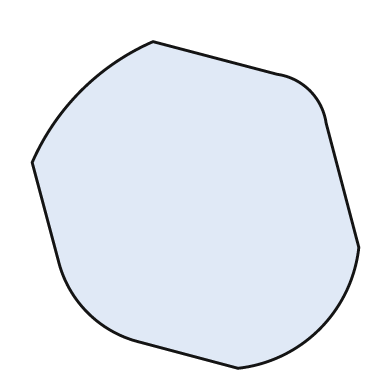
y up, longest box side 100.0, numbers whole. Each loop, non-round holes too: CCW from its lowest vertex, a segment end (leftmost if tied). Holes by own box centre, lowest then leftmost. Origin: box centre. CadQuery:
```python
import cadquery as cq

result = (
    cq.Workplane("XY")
    .moveTo(13.0, -50.0)
    .threePointArc((38.0, -38.0), (50.0, -13.0))
    .lineTo(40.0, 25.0)
    .threePointArc((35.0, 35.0), (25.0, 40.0))
    .lineTo(-13.0, 50.0)
    .threePointArc((-35.0, 35.0), (-50.0, 13.0))
    .lineTo(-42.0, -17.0)
    .threePointArc((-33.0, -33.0), (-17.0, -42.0))
    .close()
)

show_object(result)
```